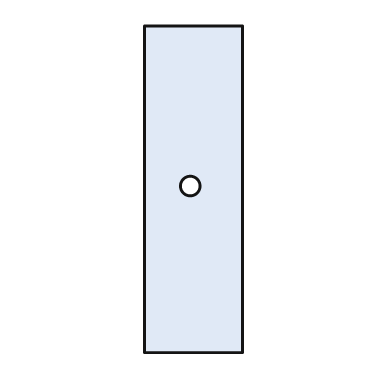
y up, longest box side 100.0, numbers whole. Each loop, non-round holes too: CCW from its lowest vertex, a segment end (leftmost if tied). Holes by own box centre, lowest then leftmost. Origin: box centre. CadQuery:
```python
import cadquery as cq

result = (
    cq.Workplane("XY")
    .moveTo(-15.0, -50.0)
    .lineTo(15.0, -50.0)
    .lineTo(15.0, 50.0)
    .lineTo(-15.0, 50.0)
    .close()
    .moveTo(-1.0, 1.0)
    .circle(3.0)
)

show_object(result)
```